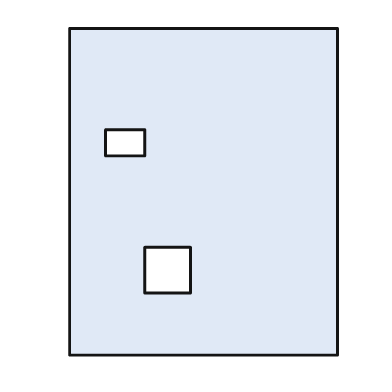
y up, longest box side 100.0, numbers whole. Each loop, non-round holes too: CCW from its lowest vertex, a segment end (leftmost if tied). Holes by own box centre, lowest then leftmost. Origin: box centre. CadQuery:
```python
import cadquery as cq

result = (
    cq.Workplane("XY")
    .moveTo(-41.0, -50.0)
    .lineTo(41.0, -50.0)
    .lineTo(41.0, 50.0)
    .lineTo(-41.0, 50.0)
    .close()
    .moveTo(-18.0, -31.0)
    .lineTo(-4.0, -31.0)
    .lineTo(-4.0, -17.0)
    .lineTo(-18.0, -17.0)
    .close()
    .moveTo(-30.0, 11.0)
    .lineTo(-18.0, 11.0)
    .lineTo(-18.0, 19.0)
    .lineTo(-30.0, 19.0)
    .close()
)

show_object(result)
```